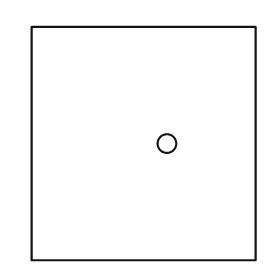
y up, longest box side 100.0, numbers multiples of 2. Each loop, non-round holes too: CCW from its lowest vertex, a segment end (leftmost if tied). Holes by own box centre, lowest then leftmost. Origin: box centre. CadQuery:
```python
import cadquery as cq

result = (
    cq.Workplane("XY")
    .moveTo(-48.0, -50.0)
    .lineTo(48.0, -50.0)
    .lineTo(48.0, 50.0)
    .lineTo(-48.0, 50.0)
    .close()
    .moveTo(10.0, 0.0)
    .circle(4.0)
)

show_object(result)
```